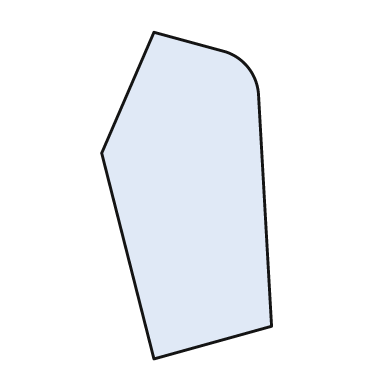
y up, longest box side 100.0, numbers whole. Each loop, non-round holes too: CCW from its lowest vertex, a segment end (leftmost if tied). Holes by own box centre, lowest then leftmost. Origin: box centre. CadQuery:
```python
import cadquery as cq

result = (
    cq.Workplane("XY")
    .moveTo(-10.0, -50.0)
    .lineTo(26.0, -40.0)
    .lineTo(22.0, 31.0)
    .threePointArc((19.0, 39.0), (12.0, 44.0))
    .lineTo(-10.0, 50.0)
    .lineTo(-26.0, 13.0)
    .close()
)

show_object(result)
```